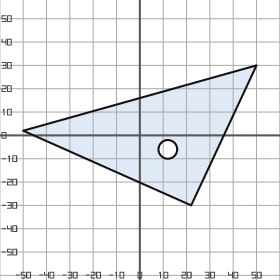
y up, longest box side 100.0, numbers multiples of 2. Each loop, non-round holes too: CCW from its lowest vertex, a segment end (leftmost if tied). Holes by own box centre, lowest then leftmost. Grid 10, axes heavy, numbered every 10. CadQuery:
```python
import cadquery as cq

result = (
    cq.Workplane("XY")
    .moveTo(22.0, -30.0)
    .lineTo(50.0, 30.0)
    .lineTo(-50.0, 2.0)
    .close()
    .moveTo(12.0, -6.0)
    .circle(4.0)
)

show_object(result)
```